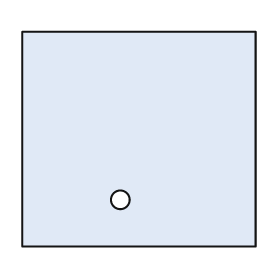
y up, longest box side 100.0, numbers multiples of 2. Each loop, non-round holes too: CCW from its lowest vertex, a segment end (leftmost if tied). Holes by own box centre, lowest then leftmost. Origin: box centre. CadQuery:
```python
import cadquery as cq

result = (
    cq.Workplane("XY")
    .moveTo(-50.0, -46.0)
    .lineTo(50.0, -46.0)
    .lineTo(50.0, 46.0)
    .lineTo(-50.0, 46.0)
    .close()
    .moveTo(-8.0, -26.0)
    .circle(4.0)
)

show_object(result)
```